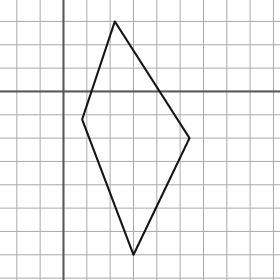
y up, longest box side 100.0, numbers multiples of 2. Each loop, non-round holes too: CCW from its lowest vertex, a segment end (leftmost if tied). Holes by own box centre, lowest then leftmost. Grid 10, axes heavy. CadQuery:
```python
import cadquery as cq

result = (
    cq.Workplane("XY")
    .moveTo(30.0, -70.0)
    .lineTo(54.0, -20.0)
    .lineTo(22.0, 30.0)
    .lineTo(8.0, -12.0)
    .close()
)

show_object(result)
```